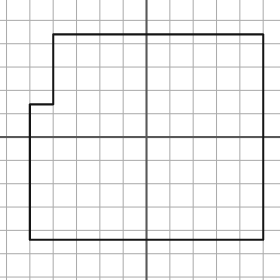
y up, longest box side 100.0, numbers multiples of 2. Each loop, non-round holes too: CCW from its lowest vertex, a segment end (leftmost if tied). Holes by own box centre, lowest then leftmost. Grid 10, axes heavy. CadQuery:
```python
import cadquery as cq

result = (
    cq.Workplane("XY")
    .moveTo(-50.0, -44.0)
    .lineTo(50.0, -44.0)
    .lineTo(50.0, 44.0)
    .lineTo(-40.0, 44.0)
    .lineTo(-40.0, 14.0)
    .lineTo(-50.0, 14.0)
    .close()
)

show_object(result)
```